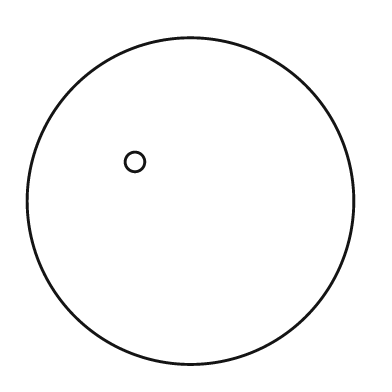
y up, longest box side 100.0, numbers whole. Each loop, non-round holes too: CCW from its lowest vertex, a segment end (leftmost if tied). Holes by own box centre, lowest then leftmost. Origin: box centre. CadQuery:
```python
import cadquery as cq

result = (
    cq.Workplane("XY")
    .moveTo(0.0, 0.0)
    .circle(50.0)
    .moveTo(-17.0, 12.0)
    .circle(3.0)
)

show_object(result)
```